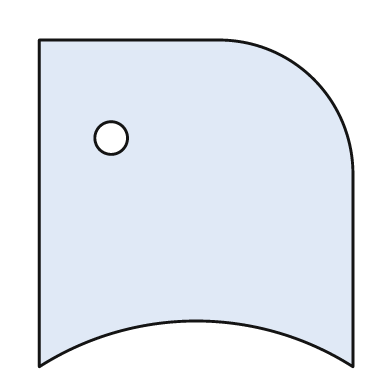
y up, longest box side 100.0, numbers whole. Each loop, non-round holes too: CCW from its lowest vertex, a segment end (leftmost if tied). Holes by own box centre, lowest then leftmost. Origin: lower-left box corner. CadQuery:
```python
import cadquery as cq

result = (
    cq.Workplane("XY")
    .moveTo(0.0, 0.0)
    .threePointArc((48.0, 14.0), (96.0, 0.0))
    .lineTo(96.0, 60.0)
    .threePointArc((84.0, 88.0), (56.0, 100.0))
    .lineTo(0.0, 100.0)
    .close()
    .moveTo(22.0, 70.0)
    .circle(5.0)
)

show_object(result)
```